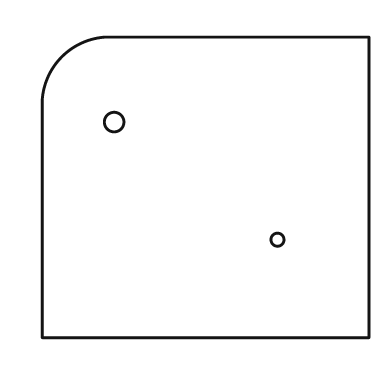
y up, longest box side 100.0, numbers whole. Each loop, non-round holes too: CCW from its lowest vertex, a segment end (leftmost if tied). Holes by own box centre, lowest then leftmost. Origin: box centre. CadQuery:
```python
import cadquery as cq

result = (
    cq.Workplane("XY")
    .moveTo(-50.0, -46.0)
    .lineTo(50.0, -46.0)
    .lineTo(50.0, 46.0)
    .lineTo(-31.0, 46.0)
    .threePointArc((-44.0, 40.0), (-50.0, 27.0))
    .close()
    .moveTo(22.0, -16.0)
    .circle(2.0)
    .moveTo(-28.0, 20.0)
    .circle(3.0)
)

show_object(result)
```